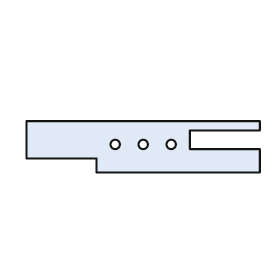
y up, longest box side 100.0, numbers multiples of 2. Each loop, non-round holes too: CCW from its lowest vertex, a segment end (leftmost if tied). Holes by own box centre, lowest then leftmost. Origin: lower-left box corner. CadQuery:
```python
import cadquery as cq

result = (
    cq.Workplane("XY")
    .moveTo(30.0, 0.0)
    .lineTo(100.0, 0.0)
    .lineTo(100.0, 10.0)
    .lineTo(70.0, 10.0)
    .lineTo(70.0, 18.0)
    .lineTo(100.0, 18.0)
    .lineTo(100.0, 22.0)
    .lineTo(0.0, 22.0)
    .lineTo(0.0, 6.0)
    .lineTo(30.0, 6.0)
    .close()
    .moveTo(38.0, 12.0)
    .circle(2.0)
    .moveTo(50.0, 12.0)
    .circle(2.0)
    .moveTo(62.0, 12.0)
    .circle(2.0)
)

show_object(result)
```